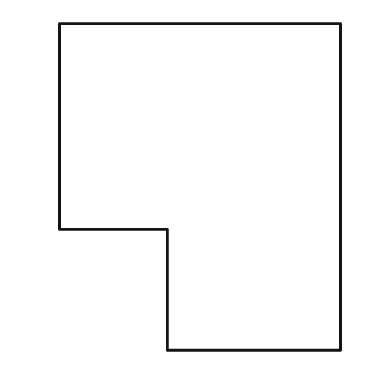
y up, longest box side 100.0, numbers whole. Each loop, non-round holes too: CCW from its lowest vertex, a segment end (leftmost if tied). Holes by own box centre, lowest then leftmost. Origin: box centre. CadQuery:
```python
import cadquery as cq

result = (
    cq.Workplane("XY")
    .moveTo(-10.0, -50.0)
    .lineTo(43.0, -50.0)
    .lineTo(43.0, 50.0)
    .lineTo(-43.0, 50.0)
    .lineTo(-43.0, -13.0)
    .lineTo(-10.0, -13.0)
    .close()
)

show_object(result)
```